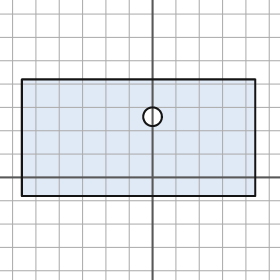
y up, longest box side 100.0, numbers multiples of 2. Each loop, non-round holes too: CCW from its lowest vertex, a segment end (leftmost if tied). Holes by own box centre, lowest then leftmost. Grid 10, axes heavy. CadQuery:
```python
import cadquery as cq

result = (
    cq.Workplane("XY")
    .moveTo(-56.0, -8.0)
    .lineTo(44.0, -8.0)
    .lineTo(44.0, 42.0)
    .lineTo(-56.0, 42.0)
    .close()
    .moveTo(0.0, 26.0)
    .circle(4.0)
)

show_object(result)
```